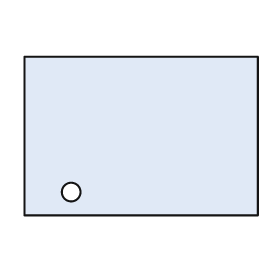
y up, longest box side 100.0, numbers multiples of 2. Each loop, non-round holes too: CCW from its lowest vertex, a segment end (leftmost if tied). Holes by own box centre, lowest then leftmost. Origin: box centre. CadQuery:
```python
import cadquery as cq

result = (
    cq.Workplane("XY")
    .moveTo(-50.0, -34.0)
    .lineTo(50.0, -34.0)
    .lineTo(50.0, 34.0)
    .lineTo(-50.0, 34.0)
    .close()
    .moveTo(-30.0, -24.0)
    .circle(4.0)
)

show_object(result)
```